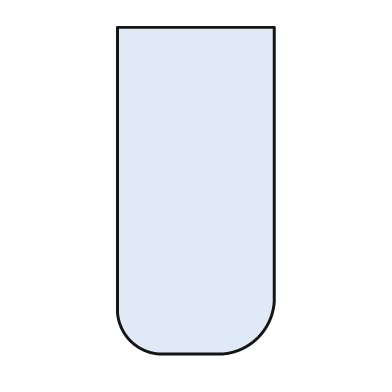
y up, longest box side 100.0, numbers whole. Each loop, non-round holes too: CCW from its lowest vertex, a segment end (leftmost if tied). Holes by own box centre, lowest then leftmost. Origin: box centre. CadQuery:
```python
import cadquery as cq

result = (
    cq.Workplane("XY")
    .moveTo(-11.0, -50.0)
    .lineTo(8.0, -50.0)
    .threePointArc((19.0, -45.0), (24.0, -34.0))
    .lineTo(24.0, 50.0)
    .lineTo(-24.0, 50.0)
    .lineTo(-24.0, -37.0)
    .threePointArc((-20.0, -46.0), (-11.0, -50.0))
    .close()
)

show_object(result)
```